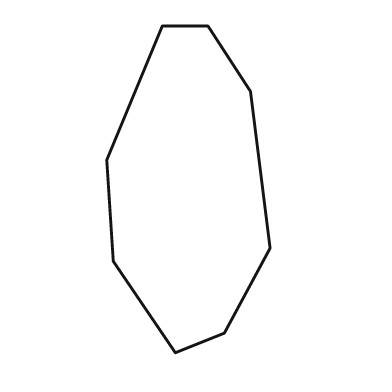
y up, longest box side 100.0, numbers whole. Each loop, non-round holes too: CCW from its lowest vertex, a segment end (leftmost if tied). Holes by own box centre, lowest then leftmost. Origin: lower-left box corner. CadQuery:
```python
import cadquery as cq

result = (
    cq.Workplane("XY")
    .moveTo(21.0, 0.0)
    .lineTo(36.0, 6.0)
    .lineTo(50.0, 32.0)
    .lineTo(44.0, 80.0)
    .lineTo(31.0, 100.0)
    .lineTo(17.0, 100.0)
    .lineTo(0.0, 59.0)
    .lineTo(2.0, 28.0)
    .close()
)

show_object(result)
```